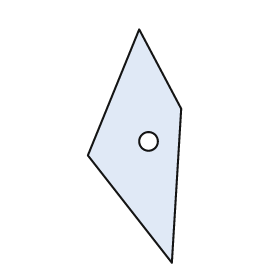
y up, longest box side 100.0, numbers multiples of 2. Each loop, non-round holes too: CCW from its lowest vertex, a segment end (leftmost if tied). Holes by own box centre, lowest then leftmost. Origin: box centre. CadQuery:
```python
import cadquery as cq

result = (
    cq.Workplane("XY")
    .moveTo(16.0, -50.0)
    .lineTo(20.0, 16.0)
    .lineTo(2.0, 50.0)
    .lineTo(-20.0, -4.0)
    .close()
    .moveTo(6.0, 2.0)
    .circle(4.0)
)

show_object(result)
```